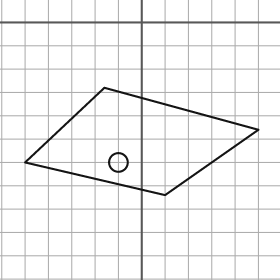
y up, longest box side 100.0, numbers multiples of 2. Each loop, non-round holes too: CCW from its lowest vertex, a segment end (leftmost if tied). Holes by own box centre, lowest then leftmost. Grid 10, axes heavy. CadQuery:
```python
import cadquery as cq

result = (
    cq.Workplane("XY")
    .moveTo(10.0, -74.0)
    .lineTo(50.0, -46.0)
    .lineTo(-16.0, -28.0)
    .lineTo(-50.0, -60.0)
    .close()
    .moveTo(-10.0, -60.0)
    .circle(4.0)
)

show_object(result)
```